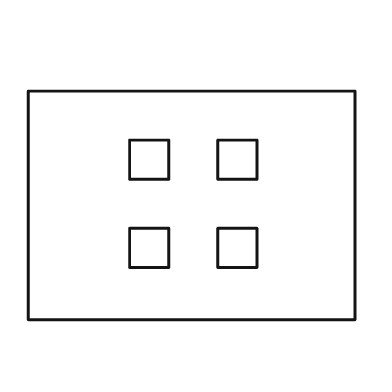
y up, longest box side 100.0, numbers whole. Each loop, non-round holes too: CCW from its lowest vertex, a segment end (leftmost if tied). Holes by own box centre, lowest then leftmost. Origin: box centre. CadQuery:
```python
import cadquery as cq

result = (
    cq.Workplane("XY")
    .moveTo(-50.0, -35.0)
    .lineTo(50.0, -35.0)
    .lineTo(50.0, 35.0)
    .lineTo(-50.0, 35.0)
    .close()
    .moveTo(-19.0, -19.0)
    .lineTo(-7.0, -19.0)
    .lineTo(-7.0, -7.0)
    .lineTo(-19.0, -7.0)
    .close()
    .moveTo(8.0, -19.0)
    .lineTo(20.0, -19.0)
    .lineTo(20.0, -7.0)
    .lineTo(8.0, -7.0)
    .close()
    .moveTo(-19.0, 8.0)
    .lineTo(-7.0, 8.0)
    .lineTo(-7.0, 20.0)
    .lineTo(-19.0, 20.0)
    .close()
    .moveTo(8.0, 8.0)
    .lineTo(20.0, 8.0)
    .lineTo(20.0, 20.0)
    .lineTo(8.0, 20.0)
    .close()
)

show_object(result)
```